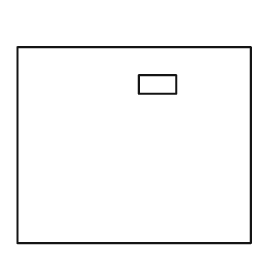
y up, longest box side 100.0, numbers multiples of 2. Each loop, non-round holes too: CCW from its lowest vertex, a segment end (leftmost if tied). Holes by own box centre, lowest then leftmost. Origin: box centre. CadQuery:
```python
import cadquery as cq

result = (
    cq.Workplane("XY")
    .moveTo(-50.0, -42.0)
    .lineTo(50.0, -42.0)
    .lineTo(50.0, 42.0)
    .lineTo(-50.0, 42.0)
    .close()
    .moveTo(2.0, 22.0)
    .lineTo(18.0, 22.0)
    .lineTo(18.0, 30.0)
    .lineTo(2.0, 30.0)
    .close()
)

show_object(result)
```